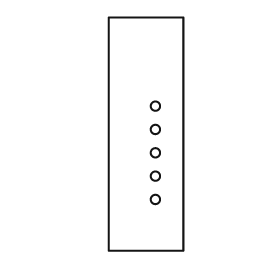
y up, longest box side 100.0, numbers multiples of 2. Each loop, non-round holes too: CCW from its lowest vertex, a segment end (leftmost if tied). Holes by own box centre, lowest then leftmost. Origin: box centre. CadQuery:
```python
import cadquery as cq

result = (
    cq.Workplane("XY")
    .moveTo(-16.0, -50.0)
    .lineTo(16.0, -50.0)
    .lineTo(16.0, 50.0)
    .lineTo(-16.0, 50.0)
    .close()
    .moveTo(4.0, -28.0)
    .circle(2.0)
    .moveTo(4.0, -18.0)
    .circle(2.0)
    .moveTo(4.0, -8.0)
    .circle(2.0)
    .moveTo(4.0, 2.0)
    .circle(2.0)
    .moveTo(4.0, 12.0)
    .circle(2.0)
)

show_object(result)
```